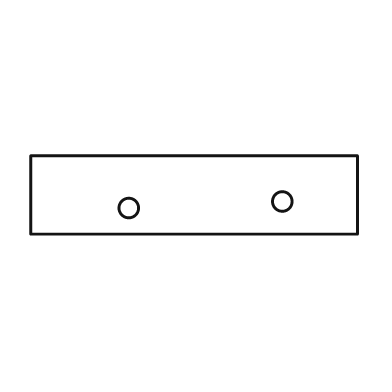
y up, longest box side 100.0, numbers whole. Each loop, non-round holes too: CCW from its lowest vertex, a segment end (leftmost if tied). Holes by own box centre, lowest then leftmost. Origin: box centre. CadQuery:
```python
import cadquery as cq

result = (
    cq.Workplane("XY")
    .moveTo(-50.0, -12.0)
    .lineTo(50.0, -12.0)
    .lineTo(50.0, 12.0)
    .lineTo(-50.0, 12.0)
    .close()
    .moveTo(-20.0, -4.0)
    .circle(3.0)
    .moveTo(27.0, -2.0)
    .circle(3.0)
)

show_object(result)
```